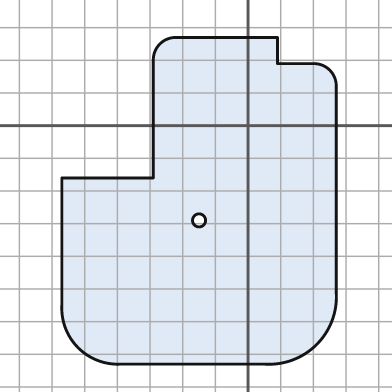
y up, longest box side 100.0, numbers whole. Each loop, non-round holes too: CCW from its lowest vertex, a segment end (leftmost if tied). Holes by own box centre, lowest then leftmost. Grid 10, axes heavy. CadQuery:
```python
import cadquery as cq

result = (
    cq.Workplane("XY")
    .moveTo(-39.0, -73.0)
    .lineTo(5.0, -73.0)
    .threePointArc((21.0, -67.0), (27.0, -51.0))
    .lineTo(27.0, 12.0)
    .threePointArc((25.0, 17.0), (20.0, 19.0))
    .lineTo(9.0, 19.0)
    .lineTo(9.0, 27.0)
    .lineTo(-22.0, 27.0)
    .threePointArc((-27.0, 25.0), (-29.0, 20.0))
    .lineTo(-29.0, -16.0)
    .lineTo(-57.0, -16.0)
    .lineTo(-57.0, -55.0)
    .threePointArc((-52.0, -68.0), (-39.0, -73.0))
    .close()
    .moveTo(-15.0, -29.0)
    .circle(2.0)
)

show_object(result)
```